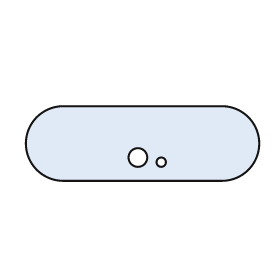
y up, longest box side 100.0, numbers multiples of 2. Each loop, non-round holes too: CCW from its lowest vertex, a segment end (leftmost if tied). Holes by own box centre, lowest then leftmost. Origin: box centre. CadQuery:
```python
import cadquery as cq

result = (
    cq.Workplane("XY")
    .moveTo(-34.0, -16.0)
    .lineTo(34.0, -16.0)
    .threePointArc((50.0, 0.0), (34.0, 16.0))
    .lineTo(-34.0, 16.0)
    .threePointArc((-50.0, 0.0), (-34.0, -16.0))
    .close()
    .moveTo(8.0, -8.0)
    .circle(2.0)
    .moveTo(-2.0, -6.0)
    .circle(4.0)
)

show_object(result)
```